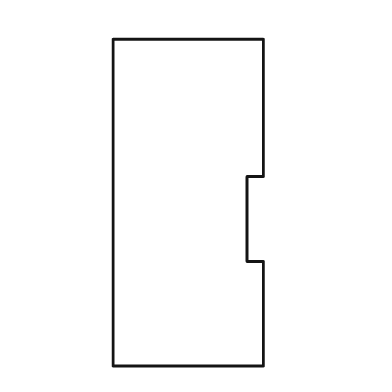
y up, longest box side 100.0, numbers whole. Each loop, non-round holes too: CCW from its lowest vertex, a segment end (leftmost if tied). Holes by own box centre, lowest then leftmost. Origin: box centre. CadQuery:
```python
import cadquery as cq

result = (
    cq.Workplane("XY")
    .moveTo(-23.0, -50.0)
    .lineTo(23.0, -50.0)
    .lineTo(23.0, -18.0)
    .lineTo(18.0, -18.0)
    .lineTo(18.0, 8.0)
    .lineTo(23.0, 8.0)
    .lineTo(23.0, 50.0)
    .lineTo(-23.0, 50.0)
    .close()
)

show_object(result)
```